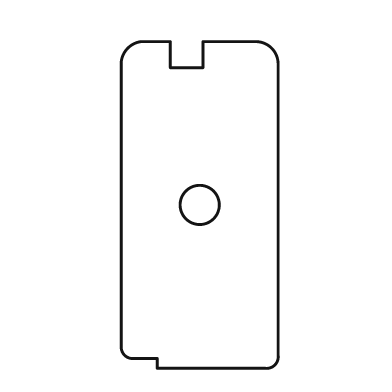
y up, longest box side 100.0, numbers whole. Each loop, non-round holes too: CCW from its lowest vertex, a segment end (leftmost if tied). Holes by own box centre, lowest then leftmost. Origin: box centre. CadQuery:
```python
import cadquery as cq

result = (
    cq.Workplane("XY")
    .moveTo(-13.0, -50.0)
    .lineTo(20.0, -50.0)
    .threePointArc((23.0, -49.0), (24.0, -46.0))
    .lineTo(24.0, 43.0)
    .threePointArc((22.0, 48.0), (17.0, 50.0))
    .lineTo(1.0, 50.0)
    .lineTo(1.0, 42.0)
    .lineTo(-9.0, 42.0)
    .lineTo(-9.0, 50.0)
    .lineTo(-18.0, 50.0)
    .threePointArc((-22.0, 48.0), (-24.0, 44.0))
    .lineTo(-24.0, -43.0)
    .threePointArc((-23.0, -46.0), (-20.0, -47.0))
    .lineTo(-13.0, -47.0)
    .close()
    .moveTo(0.0, 0.0)
    .circle(6.0)
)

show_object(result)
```